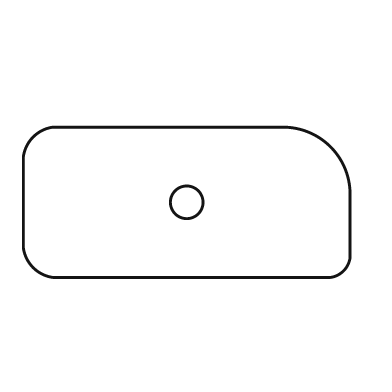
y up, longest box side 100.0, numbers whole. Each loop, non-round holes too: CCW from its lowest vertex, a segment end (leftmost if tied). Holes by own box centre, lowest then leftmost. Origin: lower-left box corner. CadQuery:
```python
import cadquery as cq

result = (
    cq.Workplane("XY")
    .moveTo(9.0, 0.0)
    .lineTo(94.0, 0.0)
    .threePointArc((98.0, 2.0), (100.0, 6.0))
    .lineTo(100.0, 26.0)
    .threePointArc((94.0, 40.0), (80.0, 46.0))
    .lineTo(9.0, 46.0)
    .threePointArc((3.0, 43.0), (0.0, 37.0))
    .lineTo(0.0, 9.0)
    .threePointArc((3.0, 3.0), (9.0, 0.0))
    .close()
    .moveTo(50.0, 23.0)
    .circle(5.0)
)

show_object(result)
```